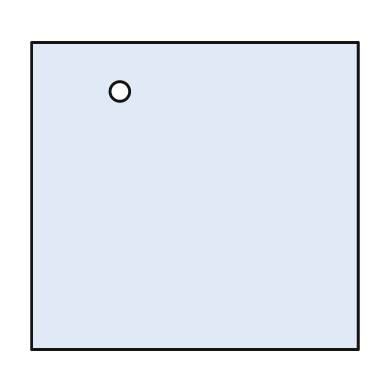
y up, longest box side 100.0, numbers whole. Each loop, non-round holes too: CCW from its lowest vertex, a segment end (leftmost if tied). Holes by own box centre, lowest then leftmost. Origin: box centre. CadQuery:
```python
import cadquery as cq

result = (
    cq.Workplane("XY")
    .moveTo(-50.0, -47.0)
    .lineTo(50.0, -47.0)
    .lineTo(50.0, 47.0)
    .lineTo(-50.0, 47.0)
    .close()
    .moveTo(-23.0, 32.0)
    .circle(3.0)
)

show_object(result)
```